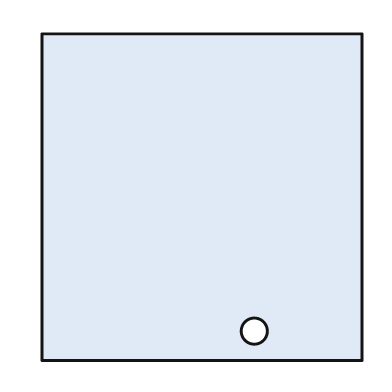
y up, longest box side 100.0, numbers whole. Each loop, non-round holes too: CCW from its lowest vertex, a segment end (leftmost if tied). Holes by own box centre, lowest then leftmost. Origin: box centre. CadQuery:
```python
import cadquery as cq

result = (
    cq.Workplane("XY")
    .moveTo(-49.0, -50.0)
    .lineTo(49.0, -50.0)
    .lineTo(49.0, 50.0)
    .lineTo(-49.0, 50.0)
    .close()
    .moveTo(16.0, -41.0)
    .circle(4.0)
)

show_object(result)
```